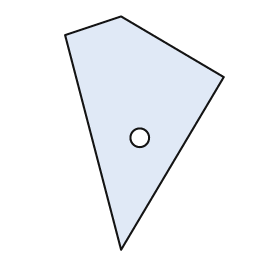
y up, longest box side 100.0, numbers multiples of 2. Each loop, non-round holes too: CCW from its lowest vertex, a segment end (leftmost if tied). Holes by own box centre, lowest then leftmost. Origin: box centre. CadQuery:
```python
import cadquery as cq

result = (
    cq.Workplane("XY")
    .moveTo(-10.0, -50.0)
    .lineTo(34.0, 24.0)
    .lineTo(-10.0, 50.0)
    .lineTo(-34.0, 42.0)
    .close()
    .moveTo(-2.0, -2.0)
    .circle(4.0)
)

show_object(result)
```